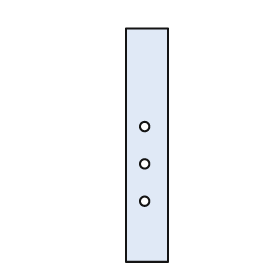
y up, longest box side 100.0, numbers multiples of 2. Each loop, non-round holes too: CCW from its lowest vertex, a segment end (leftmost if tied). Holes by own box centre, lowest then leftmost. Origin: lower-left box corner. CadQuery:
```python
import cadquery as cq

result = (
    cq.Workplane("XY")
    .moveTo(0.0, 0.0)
    .lineTo(18.0, 0.0)
    .lineTo(18.0, 100.0)
    .lineTo(0.0, 100.0)
    .close()
    .moveTo(8.0, 26.0)
    .circle(2.0)
    .moveTo(8.0, 42.0)
    .circle(2.0)
    .moveTo(8.0, 58.0)
    .circle(2.0)
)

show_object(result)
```